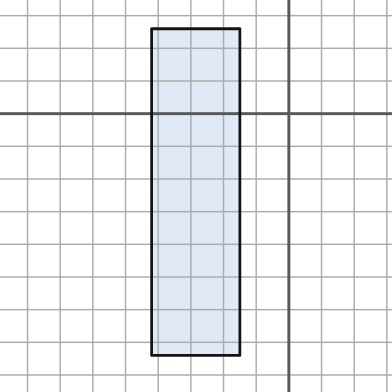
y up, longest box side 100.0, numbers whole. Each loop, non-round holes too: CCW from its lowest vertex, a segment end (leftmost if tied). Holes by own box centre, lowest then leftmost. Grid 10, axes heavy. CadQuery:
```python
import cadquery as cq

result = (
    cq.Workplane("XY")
    .moveTo(-42.0, -74.0)
    .lineTo(-15.0, -74.0)
    .lineTo(-15.0, 26.0)
    .lineTo(-42.0, 26.0)
    .close()
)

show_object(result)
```